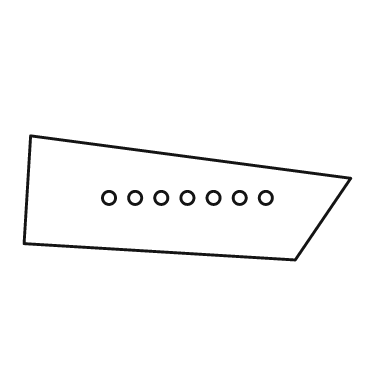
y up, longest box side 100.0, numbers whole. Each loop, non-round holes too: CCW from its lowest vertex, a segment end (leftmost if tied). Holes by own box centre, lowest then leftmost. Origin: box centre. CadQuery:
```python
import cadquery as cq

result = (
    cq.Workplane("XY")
    .moveTo(33.0, -19.0)
    .lineTo(50.0, 6.0)
    .lineTo(-48.0, 19.0)
    .lineTo(-50.0, -14.0)
    .close()
    .moveTo(-24.0, 0.0)
    .circle(2.0)
    .moveTo(-16.0, 0.0)
    .circle(2.0)
    .moveTo(-8.0, 0.0)
    .circle(2.0)
    .moveTo(0.0, 0.0)
    .circle(2.0)
    .moveTo(8.0, 0.0)
    .circle(2.0)
    .moveTo(16.0, 0.0)
    .circle(2.0)
    .moveTo(24.0, 0.0)
    .circle(2.0)
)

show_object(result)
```